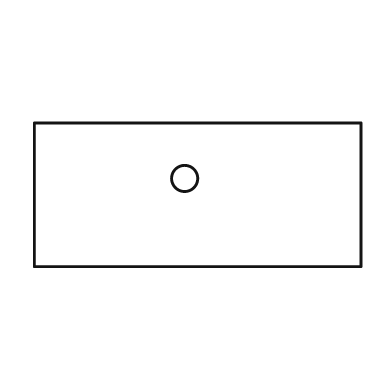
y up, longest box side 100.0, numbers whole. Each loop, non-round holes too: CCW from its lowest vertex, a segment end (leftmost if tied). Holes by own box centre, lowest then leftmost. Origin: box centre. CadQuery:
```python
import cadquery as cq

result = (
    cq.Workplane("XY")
    .moveTo(-50.0, -22.0)
    .lineTo(50.0, -22.0)
    .lineTo(50.0, 22.0)
    .lineTo(-50.0, 22.0)
    .close()
    .moveTo(-4.0, 5.0)
    .circle(4.0)
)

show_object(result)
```